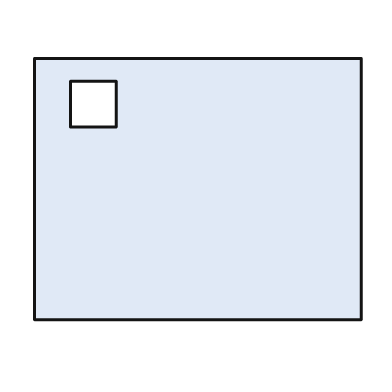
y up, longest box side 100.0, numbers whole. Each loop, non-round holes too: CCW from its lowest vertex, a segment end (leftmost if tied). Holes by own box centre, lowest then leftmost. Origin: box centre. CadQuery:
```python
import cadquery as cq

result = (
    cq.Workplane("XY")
    .moveTo(-50.0, -40.0)
    .lineTo(50.0, -40.0)
    .lineTo(50.0, 40.0)
    .lineTo(-50.0, 40.0)
    .close()
    .moveTo(-39.0, 19.0)
    .lineTo(-25.0, 19.0)
    .lineTo(-25.0, 33.0)
    .lineTo(-39.0, 33.0)
    .close()
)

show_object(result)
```